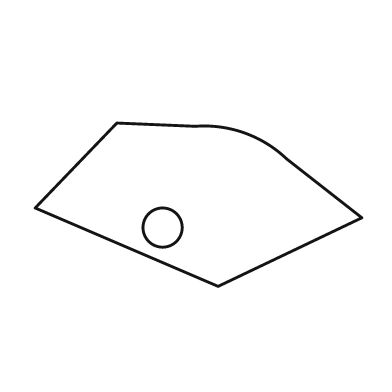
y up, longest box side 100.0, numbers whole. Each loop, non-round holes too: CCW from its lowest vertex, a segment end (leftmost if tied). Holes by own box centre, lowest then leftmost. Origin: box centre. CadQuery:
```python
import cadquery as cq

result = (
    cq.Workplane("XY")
    .moveTo(6.0, -25.0)
    .lineTo(50.0, -4.0)
    .lineTo(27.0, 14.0)
    .threePointArc((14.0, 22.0), (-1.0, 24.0))
    .lineTo(-25.0, 25.0)
    .lineTo(-50.0, -1.0)
    .close()
    .moveTo(-11.0, -7.0)
    .circle(6.0)
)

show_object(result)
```